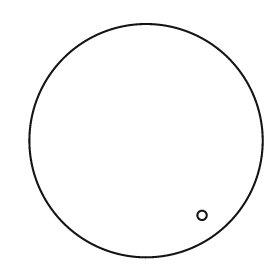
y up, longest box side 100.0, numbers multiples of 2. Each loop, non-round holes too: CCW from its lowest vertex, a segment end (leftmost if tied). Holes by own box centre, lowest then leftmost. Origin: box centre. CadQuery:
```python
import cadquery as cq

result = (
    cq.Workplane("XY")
    .moveTo(0.0, 0.0)
    .circle(50.0)
    .moveTo(24.0, -32.0)
    .circle(2.0)
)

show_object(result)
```